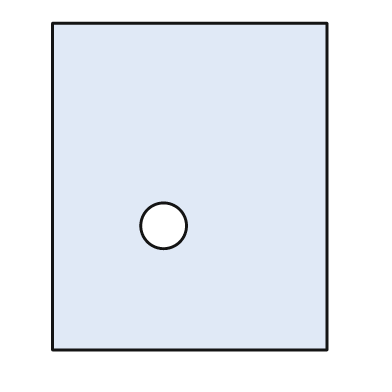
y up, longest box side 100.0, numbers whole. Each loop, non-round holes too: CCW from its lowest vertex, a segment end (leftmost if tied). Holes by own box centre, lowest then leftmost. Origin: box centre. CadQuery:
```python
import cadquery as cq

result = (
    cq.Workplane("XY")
    .moveTo(-42.0, -50.0)
    .lineTo(42.0, -50.0)
    .lineTo(42.0, 50.0)
    .lineTo(-42.0, 50.0)
    .close()
    .moveTo(-8.0, -12.0)
    .circle(7.0)
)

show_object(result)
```